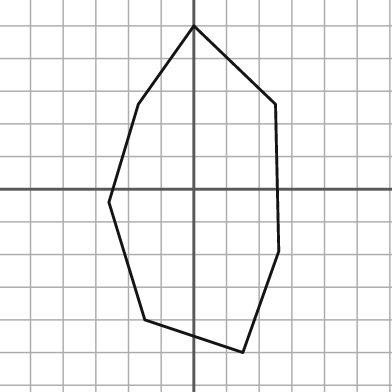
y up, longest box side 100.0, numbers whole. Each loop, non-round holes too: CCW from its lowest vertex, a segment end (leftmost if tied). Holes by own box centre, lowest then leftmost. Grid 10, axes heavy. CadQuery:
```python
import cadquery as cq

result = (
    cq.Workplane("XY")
    .moveTo(15.0, -50.0)
    .lineTo(26.0, -19.0)
    .lineTo(25.0, 26.0)
    .lineTo(0.0, 50.0)
    .lineTo(-17.0, 26.0)
    .lineTo(-26.0, -4.0)
    .lineTo(-15.0, -40.0)
    .close()
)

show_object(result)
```